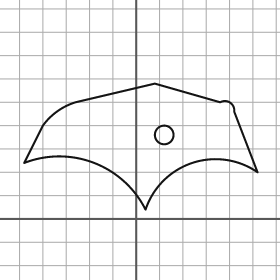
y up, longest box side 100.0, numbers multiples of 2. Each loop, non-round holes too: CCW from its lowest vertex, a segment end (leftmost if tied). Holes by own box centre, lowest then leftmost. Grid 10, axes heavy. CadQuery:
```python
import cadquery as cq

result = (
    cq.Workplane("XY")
    .moveTo(4.0, 4.0)
    .threePointArc((24.0, 24.0), (52.0, 20.0))
    .lineTo(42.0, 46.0)
    .threePointArc((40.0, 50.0), (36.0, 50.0))
    .lineTo(8.0, 58.0)
    .lineTo(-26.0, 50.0)
    .threePointArc((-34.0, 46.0), (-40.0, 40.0))
    .lineTo(-48.0, 24.0)
    .threePointArc((-18.0, 24.0), (4.0, 4.0))
    .close()
    .moveTo(12.0, 36.0)
    .circle(4.0)
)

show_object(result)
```